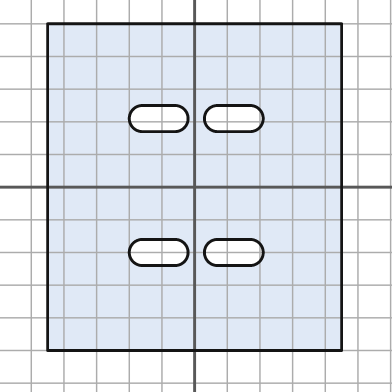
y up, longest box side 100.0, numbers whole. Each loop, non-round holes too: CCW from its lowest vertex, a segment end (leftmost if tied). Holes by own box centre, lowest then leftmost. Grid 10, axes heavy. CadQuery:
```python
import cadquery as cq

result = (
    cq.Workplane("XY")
    .moveTo(-45.0, -50.0)
    .lineTo(45.0, -50.0)
    .lineTo(45.0, 50.0)
    .lineTo(-45.0, 50.0)
    .close()
    .moveTo(-16.0, -24.0)
    .lineTo(-6.0, -24.0)
    .threePointArc((-2.0, -20.0), (-6.0, -16.0))
    .lineTo(-16.0, -16.0)
    .threePointArc((-20.0, -20.0), (-16.0, -24.0))
    .close()
    .moveTo(7.0, -24.0)
    .lineTo(17.0, -24.0)
    .threePointArc((21.0, -20.0), (17.0, -16.0))
    .lineTo(7.0, -16.0)
    .threePointArc((3.0, -20.0), (7.0, -24.0))
    .close()
    .moveTo(-16.0, 17.0)
    .lineTo(-6.0, 17.0)
    .threePointArc((-2.0, 21.0), (-6.0, 25.0))
    .lineTo(-16.0, 25.0)
    .threePointArc((-20.0, 21.0), (-16.0, 17.0))
    .close()
    .moveTo(7.0, 17.0)
    .lineTo(17.0, 17.0)
    .threePointArc((21.0, 21.0), (17.0, 25.0))
    .lineTo(7.0, 25.0)
    .threePointArc((3.0, 21.0), (7.0, 17.0))
    .close()
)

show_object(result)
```